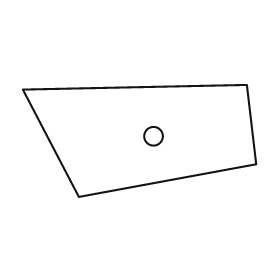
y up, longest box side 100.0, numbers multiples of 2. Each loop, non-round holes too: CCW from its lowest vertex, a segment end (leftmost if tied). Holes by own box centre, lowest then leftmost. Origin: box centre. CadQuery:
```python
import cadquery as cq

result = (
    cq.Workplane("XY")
    .moveTo(-26.0, -24.0)
    .lineTo(50.0, -10.0)
    .lineTo(46.0, 24.0)
    .lineTo(-50.0, 22.0)
    .close()
    .moveTo(6.0, 2.0)
    .circle(4.0)
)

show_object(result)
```